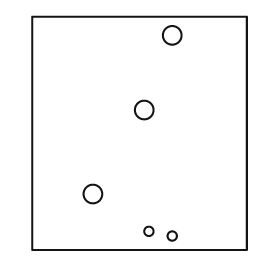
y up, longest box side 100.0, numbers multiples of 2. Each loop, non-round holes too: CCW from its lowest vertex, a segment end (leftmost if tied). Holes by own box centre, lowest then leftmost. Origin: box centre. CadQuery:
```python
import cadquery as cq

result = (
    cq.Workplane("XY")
    .moveTo(-46.0, -50.0)
    .lineTo(46.0, -50.0)
    .lineTo(46.0, 50.0)
    .lineTo(-46.0, 50.0)
    .close()
    .moveTo(14.0, -44.0)
    .circle(2.0)
    .moveTo(4.0, -42.0)
    .circle(2.0)
    .moveTo(-20.0, -26.0)
    .circle(4.0)
    .moveTo(2.0, 10.0)
    .circle(4.0)
    .moveTo(14.0, 42.0)
    .circle(4.0)
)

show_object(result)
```